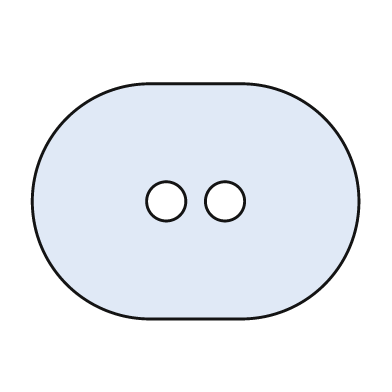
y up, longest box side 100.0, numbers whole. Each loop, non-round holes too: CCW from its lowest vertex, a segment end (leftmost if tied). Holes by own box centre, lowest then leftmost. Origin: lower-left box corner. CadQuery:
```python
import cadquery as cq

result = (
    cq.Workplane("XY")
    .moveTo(36.0, 0.0)
    .lineTo(64.0, 0.0)
    .threePointArc((100.0, 36.0), (64.0, 72.0))
    .lineTo(36.0, 72.0)
    .threePointArc((0.0, 36.0), (36.0, 0.0))
    .close()
    .moveTo(41.0, 36.0)
    .circle(6.0)
    .moveTo(59.0, 36.0)
    .circle(6.0)
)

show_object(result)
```